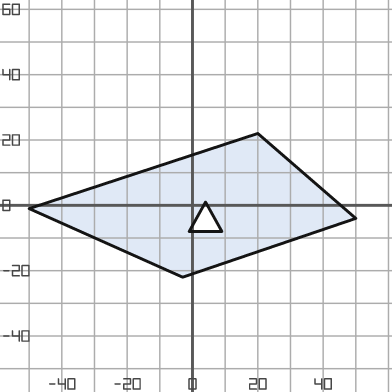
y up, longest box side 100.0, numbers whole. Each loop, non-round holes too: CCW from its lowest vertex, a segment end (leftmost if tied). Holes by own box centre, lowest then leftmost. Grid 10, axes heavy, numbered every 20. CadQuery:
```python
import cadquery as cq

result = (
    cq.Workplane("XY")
    .moveTo(-3.0, -22.0)
    .lineTo(50.0, -4.0)
    .lineTo(20.0, 22.0)
    .lineTo(-50.0, -1.0)
    .close()
    .moveTo(-1.0, -8.0)
    .lineTo(9.0, -8.0)
    .lineTo(4.0, 1.0)
    .close()
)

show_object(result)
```